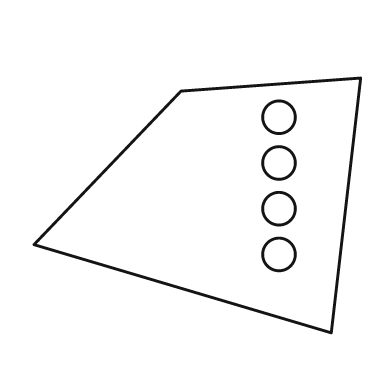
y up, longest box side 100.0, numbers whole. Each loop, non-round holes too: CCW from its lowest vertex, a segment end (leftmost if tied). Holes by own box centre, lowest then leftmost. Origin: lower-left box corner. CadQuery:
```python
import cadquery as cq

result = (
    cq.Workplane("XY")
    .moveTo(91.0, 0.0)
    .lineTo(100.0, 78.0)
    .lineTo(45.0, 74.0)
    .lineTo(0.0, 27.0)
    .close()
    .moveTo(75.0, 24.0)
    .circle(5.0)
    .moveTo(75.0, 38.0)
    .circle(5.0)
    .moveTo(75.0, 52.0)
    .circle(5.0)
    .moveTo(75.0, 66.0)
    .circle(5.0)
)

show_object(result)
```